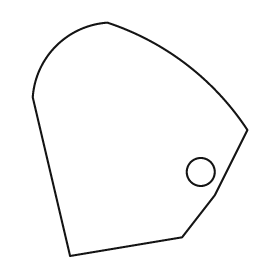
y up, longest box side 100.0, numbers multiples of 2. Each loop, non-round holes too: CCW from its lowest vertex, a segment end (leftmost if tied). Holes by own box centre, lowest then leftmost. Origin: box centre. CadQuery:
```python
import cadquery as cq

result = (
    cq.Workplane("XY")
    .moveTo(-30.0, -50.0)
    .lineTo(18.0, -42.0)
    .lineTo(32.0, -24.0)
    .lineTo(46.0, 4.0)
    .threePointArc((20.0, 32.0), (-14.0, 50.0))
    .threePointArc((-36.0, 40.0), (-46.0, 18.0))
    .close()
    .moveTo(26.0, -14.0)
    .circle(6.0)
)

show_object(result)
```